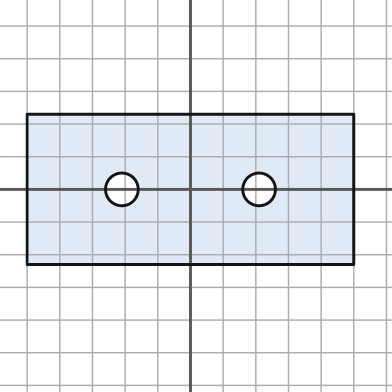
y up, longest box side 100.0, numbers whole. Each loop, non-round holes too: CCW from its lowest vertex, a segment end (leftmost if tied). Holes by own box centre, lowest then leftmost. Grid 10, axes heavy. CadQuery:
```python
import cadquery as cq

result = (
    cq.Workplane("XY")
    .moveTo(-50.0, -23.0)
    .lineTo(50.0, -23.0)
    .lineTo(50.0, 23.0)
    .lineTo(-50.0, 23.0)
    .close()
    .moveTo(-21.0, 0.0)
    .circle(5.0)
    .moveTo(21.0, 0.0)
    .circle(5.0)
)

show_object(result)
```